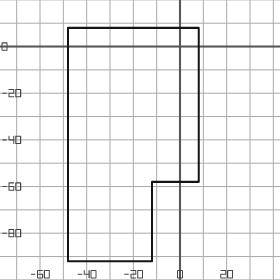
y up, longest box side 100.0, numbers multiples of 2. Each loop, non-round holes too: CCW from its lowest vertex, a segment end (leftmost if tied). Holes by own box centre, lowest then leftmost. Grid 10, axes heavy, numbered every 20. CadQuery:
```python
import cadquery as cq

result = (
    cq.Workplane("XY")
    .moveTo(-48.0, -92.0)
    .lineTo(-12.0, -92.0)
    .lineTo(-12.0, -58.0)
    .lineTo(8.0, -58.0)
    .lineTo(8.0, 8.0)
    .lineTo(-48.0, 8.0)
    .close()
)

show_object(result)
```